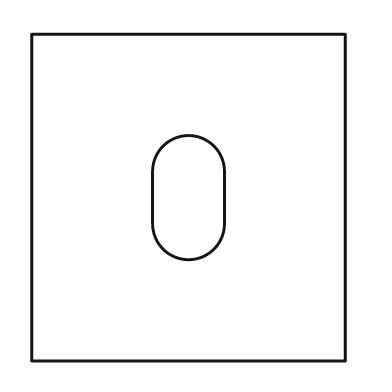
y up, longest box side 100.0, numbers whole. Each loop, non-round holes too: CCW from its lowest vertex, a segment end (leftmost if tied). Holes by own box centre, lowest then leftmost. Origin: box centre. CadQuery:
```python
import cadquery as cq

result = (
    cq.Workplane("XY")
    .moveTo(-48.0, -50.0)
    .lineTo(48.0, -50.0)
    .lineTo(48.0, 50.0)
    .lineTo(-48.0, 50.0)
    .close()
    .moveTo(-11.0, -8.0)
    .threePointArc((0.0, -19.0), (11.0, -8.0))
    .lineTo(11.0, 8.0)
    .threePointArc((0.0, 19.0), (-11.0, 8.0))
    .close()
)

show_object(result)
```